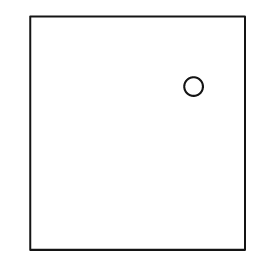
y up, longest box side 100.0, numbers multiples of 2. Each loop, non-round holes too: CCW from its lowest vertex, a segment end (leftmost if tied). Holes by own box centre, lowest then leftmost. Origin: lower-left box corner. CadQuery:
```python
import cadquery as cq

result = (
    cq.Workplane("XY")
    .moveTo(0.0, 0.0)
    .lineTo(92.0, 0.0)
    .lineTo(92.0, 100.0)
    .lineTo(0.0, 100.0)
    .close()
    .moveTo(70.0, 70.0)
    .circle(4.0)
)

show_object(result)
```